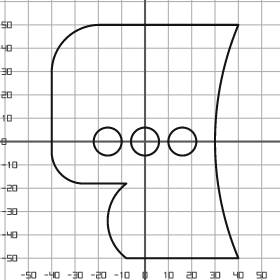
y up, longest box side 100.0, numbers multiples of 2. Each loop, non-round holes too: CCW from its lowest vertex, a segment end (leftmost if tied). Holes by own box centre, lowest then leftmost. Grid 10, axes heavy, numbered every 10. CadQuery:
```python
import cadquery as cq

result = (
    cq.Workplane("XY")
    .moveTo(-8.0, -50.0)
    .lineTo(40.0, -50.0)
    .threePointArc((30.0, 0.0), (40.0, 50.0))
    .lineTo(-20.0, 50.0)
    .threePointArc((-34.0, 44.0), (-40.0, 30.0))
    .lineTo(-40.0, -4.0)
    .threePointArc((-36.0, -14.0), (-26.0, -18.0))
    .lineTo(-8.0, -18.0)
    .threePointArc((-16.0, -34.0), (-8.0, -50.0))
    .close()
    .moveTo(-16.0, 0.0)
    .circle(6.0)
    .moveTo(0.0, 0.0)
    .circle(6.0)
    .moveTo(16.0, 0.0)
    .circle(6.0)
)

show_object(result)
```